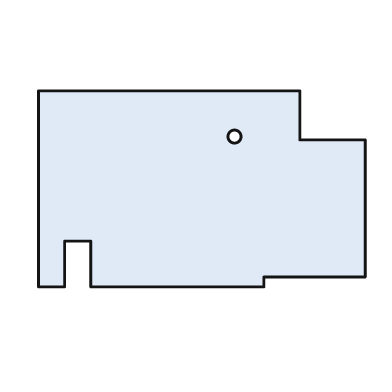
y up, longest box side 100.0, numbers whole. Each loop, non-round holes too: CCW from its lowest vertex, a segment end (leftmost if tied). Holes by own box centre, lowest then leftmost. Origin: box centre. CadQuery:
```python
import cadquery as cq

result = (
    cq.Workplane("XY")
    .moveTo(-50.0, -30.0)
    .lineTo(-42.0, -30.0)
    .lineTo(-42.0, -16.0)
    .lineTo(-34.0, -16.0)
    .lineTo(-34.0, -30.0)
    .lineTo(19.0, -30.0)
    .lineTo(19.0, -27.0)
    .lineTo(50.0, -27.0)
    .lineTo(50.0, 15.0)
    .lineTo(30.0, 15.0)
    .lineTo(30.0, 30.0)
    .lineTo(-50.0, 30.0)
    .close()
    .moveTo(10.0, 16.0)
    .circle(2.0)
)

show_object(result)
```